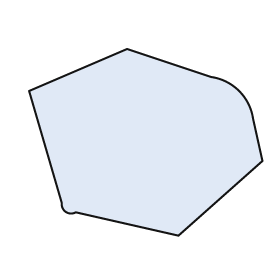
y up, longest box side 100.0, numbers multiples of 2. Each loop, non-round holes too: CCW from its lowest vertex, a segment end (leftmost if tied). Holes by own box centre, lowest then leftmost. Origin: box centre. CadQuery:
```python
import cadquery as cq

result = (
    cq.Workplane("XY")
    .moveTo(14.0, -40.0)
    .lineTo(50.0, -8.0)
    .lineTo(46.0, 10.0)
    .threePointArc((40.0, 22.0), (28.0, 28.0))
    .lineTo(-8.0, 40.0)
    .lineTo(-50.0, 22.0)
    .lineTo(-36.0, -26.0)
    .threePointArc((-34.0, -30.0), (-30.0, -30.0))
    .close()
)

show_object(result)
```